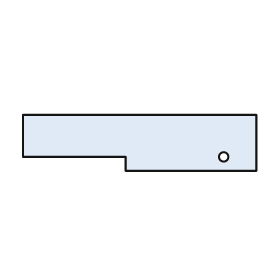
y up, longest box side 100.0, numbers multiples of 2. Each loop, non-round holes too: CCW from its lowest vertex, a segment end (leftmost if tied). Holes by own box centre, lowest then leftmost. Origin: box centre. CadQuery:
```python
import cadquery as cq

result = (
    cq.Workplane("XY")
    .moveTo(-6.0, -12.0)
    .lineTo(50.0, -12.0)
    .lineTo(50.0, 12.0)
    .lineTo(-50.0, 12.0)
    .lineTo(-50.0, -6.0)
    .lineTo(-6.0, -6.0)
    .close()
    .moveTo(36.0, -6.0)
    .circle(2.0)
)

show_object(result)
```